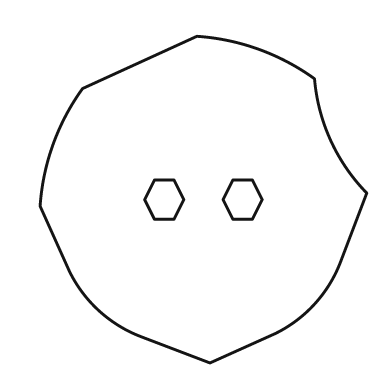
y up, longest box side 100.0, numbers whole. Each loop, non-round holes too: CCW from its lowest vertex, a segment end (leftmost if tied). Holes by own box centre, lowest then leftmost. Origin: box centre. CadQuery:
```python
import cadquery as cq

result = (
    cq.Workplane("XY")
    .moveTo(2.0, -50.0)
    .lineTo(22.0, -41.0)
    .threePointArc((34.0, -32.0), (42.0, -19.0))
    .lineTo(50.0, 2.0)
    .threePointArc((39.0, 18.0), (34.0, 37.0))
    .threePointArc((17.0, 46.0), (-2.0, 50.0))
    .lineTo(-37.0, 34.0)
    .threePointArc((-46.0, 17.0), (-50.0, -2.0))
    .lineTo(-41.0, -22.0)
    .threePointArc((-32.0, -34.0), (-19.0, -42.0))
    .close()
    .moveTo(-15.0, -6.0)
    .lineTo(-9.0, -6.0)
    .lineTo(-6.0, 0.0)
    .lineTo(-9.0, 6.0)
    .lineTo(-15.0, 6.0)
    .lineTo(-18.0, 0.0)
    .close()
    .moveTo(9.0, -6.0)
    .lineTo(15.0, -6.0)
    .lineTo(18.0, 0.0)
    .lineTo(15.0, 6.0)
    .lineTo(9.0, 6.0)
    .lineTo(6.0, 0.0)
    .close()
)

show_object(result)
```